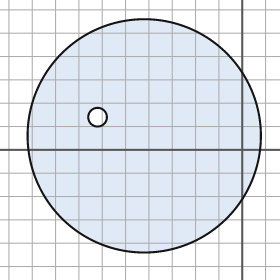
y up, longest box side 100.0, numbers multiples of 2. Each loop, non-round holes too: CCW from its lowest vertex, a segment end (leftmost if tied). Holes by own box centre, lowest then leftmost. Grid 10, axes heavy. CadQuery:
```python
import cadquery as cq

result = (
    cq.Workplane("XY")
    .moveTo(-42.0, 6.0)
    .circle(50.0)
    .moveTo(-62.0, 14.0)
    .circle(4.0)
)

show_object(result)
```